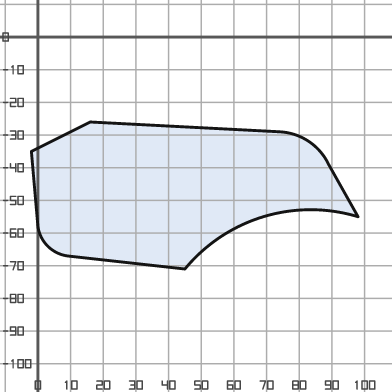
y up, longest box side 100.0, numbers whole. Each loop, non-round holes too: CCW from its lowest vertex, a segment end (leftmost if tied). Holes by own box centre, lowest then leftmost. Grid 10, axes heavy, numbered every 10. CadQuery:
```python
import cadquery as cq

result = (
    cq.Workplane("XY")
    .moveTo(45.0, -71.0)
    .threePointArc((69.0, -55.0), (98.0, -55.0))
    .lineTo(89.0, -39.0)
    .threePointArc((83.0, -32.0), (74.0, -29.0))
    .lineTo(16.0, -26.0)
    .lineTo(-2.0, -35.0)
    .lineTo(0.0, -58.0)
    .threePointArc((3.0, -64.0), (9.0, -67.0))
    .close()
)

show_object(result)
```